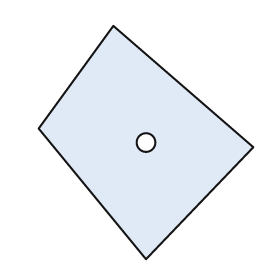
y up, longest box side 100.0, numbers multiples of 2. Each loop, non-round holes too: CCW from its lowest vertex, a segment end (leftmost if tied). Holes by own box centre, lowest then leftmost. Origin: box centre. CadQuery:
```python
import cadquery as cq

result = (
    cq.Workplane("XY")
    .moveTo(0.0, -50.0)
    .lineTo(46.0, -2.0)
    .lineTo(-14.0, 50.0)
    .lineTo(-46.0, 6.0)
    .close()
    .moveTo(0.0, 0.0)
    .circle(4.0)
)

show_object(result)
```